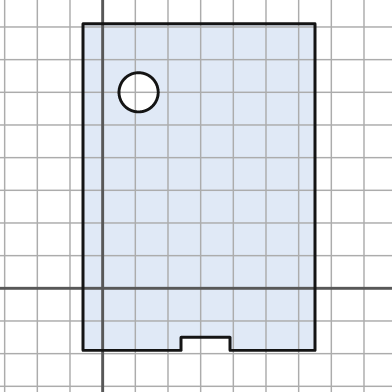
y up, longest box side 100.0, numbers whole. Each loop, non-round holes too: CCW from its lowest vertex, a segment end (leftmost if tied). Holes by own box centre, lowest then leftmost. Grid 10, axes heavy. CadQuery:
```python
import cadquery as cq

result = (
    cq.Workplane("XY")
    .moveTo(-6.0, -19.0)
    .lineTo(24.0, -19.0)
    .lineTo(24.0, -15.0)
    .lineTo(39.0, -15.0)
    .lineTo(39.0, -19.0)
    .lineTo(65.0, -19.0)
    .lineTo(65.0, 81.0)
    .lineTo(-6.0, 81.0)
    .close()
    .moveTo(11.0, 60.0)
    .circle(6.0)
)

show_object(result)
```